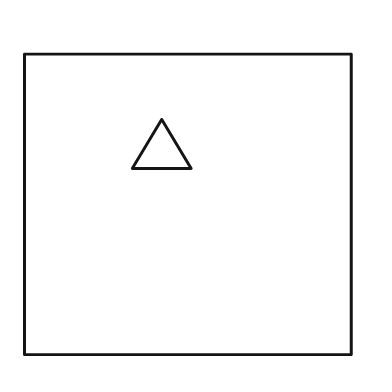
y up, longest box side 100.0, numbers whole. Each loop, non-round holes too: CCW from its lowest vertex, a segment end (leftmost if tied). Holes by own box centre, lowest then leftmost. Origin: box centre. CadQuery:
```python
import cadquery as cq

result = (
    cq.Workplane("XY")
    .moveTo(-50.0, -46.0)
    .lineTo(50.0, -46.0)
    .lineTo(50.0, 46.0)
    .lineTo(-50.0, 46.0)
    .close()
    .moveTo(-17.0, 11.0)
    .lineTo(1.0, 11.0)
    .lineTo(-8.0, 26.0)
    .close()
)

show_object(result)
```